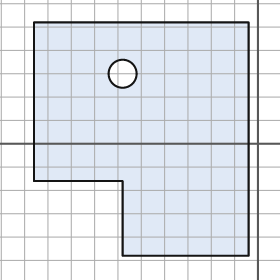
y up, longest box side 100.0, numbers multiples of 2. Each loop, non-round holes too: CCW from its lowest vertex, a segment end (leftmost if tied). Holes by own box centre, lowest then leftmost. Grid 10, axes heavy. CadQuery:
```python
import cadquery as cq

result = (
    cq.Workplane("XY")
    .moveTo(-58.0, -48.0)
    .lineTo(-4.0, -48.0)
    .lineTo(-4.0, 52.0)
    .lineTo(-96.0, 52.0)
    .lineTo(-96.0, -16.0)
    .lineTo(-58.0, -16.0)
    .close()
    .moveTo(-58.0, 30.0)
    .circle(6.0)
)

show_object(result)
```